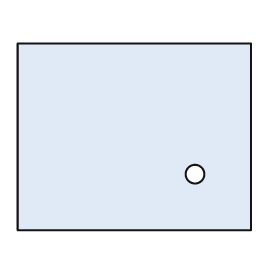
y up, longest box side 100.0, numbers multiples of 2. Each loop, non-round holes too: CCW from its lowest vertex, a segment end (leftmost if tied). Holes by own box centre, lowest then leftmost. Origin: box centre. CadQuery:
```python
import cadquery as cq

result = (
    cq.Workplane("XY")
    .moveTo(-50.0, -40.0)
    .lineTo(50.0, -40.0)
    .lineTo(50.0, 40.0)
    .lineTo(-50.0, 40.0)
    .close()
    .moveTo(26.0, -16.0)
    .circle(4.0)
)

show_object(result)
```